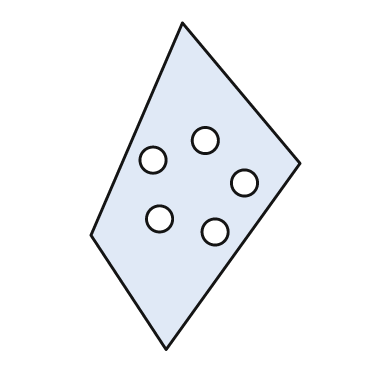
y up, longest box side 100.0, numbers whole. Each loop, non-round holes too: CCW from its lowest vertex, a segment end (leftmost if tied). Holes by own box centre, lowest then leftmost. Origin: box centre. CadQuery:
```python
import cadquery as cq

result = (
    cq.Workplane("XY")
    .moveTo(-9.0, -50.0)
    .lineTo(32.0, 7.0)
    .lineTo(-4.0, 50.0)
    .lineTo(-32.0, -15.0)
    .close()
    .moveTo(6.0, -14.0)
    .circle(4.0)
    .moveTo(-11.0, -10.0)
    .circle(4.0)
    .moveTo(15.0, 1.0)
    .circle(4.0)
    .moveTo(-13.0, 8.0)
    .circle(4.0)
    .moveTo(3.0, 14.0)
    .circle(4.0)
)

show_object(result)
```